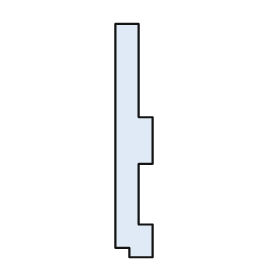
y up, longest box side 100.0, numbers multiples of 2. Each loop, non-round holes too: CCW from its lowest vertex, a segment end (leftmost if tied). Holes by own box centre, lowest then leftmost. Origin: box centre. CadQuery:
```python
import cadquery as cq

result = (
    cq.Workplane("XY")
    .moveTo(-2.0, -50.0)
    .lineTo(8.0, -50.0)
    .lineTo(8.0, -36.0)
    .lineTo(2.0, -36.0)
    .lineTo(2.0, -10.0)
    .lineTo(8.0, -10.0)
    .lineTo(8.0, 10.0)
    .lineTo(2.0, 10.0)
    .lineTo(2.0, 50.0)
    .lineTo(-8.0, 50.0)
    .lineTo(-8.0, -46.0)
    .lineTo(-2.0, -46.0)
    .close()
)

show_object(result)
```